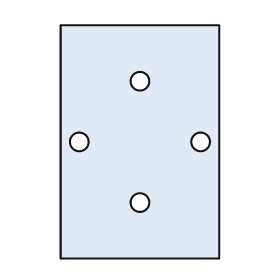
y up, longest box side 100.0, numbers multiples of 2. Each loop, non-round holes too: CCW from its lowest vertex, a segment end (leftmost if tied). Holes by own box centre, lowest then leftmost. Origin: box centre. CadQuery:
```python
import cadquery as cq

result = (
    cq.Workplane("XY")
    .moveTo(-34.0, -50.0)
    .lineTo(34.0, -50.0)
    .lineTo(34.0, 50.0)
    .lineTo(-34.0, 50.0)
    .close()
    .moveTo(0.0, -26.0)
    .circle(4.0)
    .moveTo(-26.0, 0.0)
    .circle(4.0)
    .moveTo(26.0, 0.0)
    .circle(4.0)
    .moveTo(0.0, 26.0)
    .circle(4.0)
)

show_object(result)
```